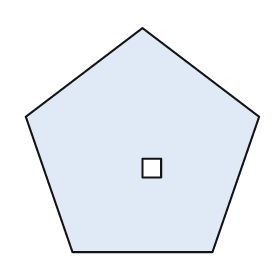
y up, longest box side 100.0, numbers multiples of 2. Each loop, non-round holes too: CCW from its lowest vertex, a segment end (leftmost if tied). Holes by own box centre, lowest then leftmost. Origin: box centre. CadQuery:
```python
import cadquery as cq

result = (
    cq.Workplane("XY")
    .moveTo(-30.0, -48.0)
    .lineTo(30.0, -48.0)
    .lineTo(50.0, 10.0)
    .lineTo(0.0, 48.0)
    .lineTo(-50.0, 10.0)
    .close()
    .moveTo(0.0, -16.0)
    .lineTo(8.0, -16.0)
    .lineTo(8.0, -8.0)
    .lineTo(0.0, -8.0)
    .close()
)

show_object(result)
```